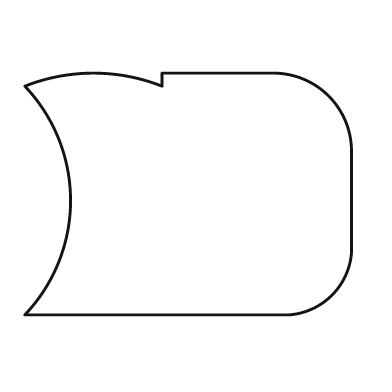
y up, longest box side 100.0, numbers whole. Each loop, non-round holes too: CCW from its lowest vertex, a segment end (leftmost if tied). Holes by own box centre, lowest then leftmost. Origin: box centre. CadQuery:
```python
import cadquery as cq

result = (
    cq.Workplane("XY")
    .moveTo(-50.0, -37.0)
    .lineTo(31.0, -37.0)
    .threePointArc((44.0, -31.0), (50.0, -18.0))
    .lineTo(50.0, 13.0)
    .threePointArc((43.0, 30.0), (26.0, 37.0))
    .lineTo(-8.0, 37.0)
    .lineTo(-8.0, 33.0)
    .threePointArc((-29.0, 37.0), (-50.0, 33.0))
    .threePointArc((-36.0, -2.0), (-50.0, -37.0))
    .close()
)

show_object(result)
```